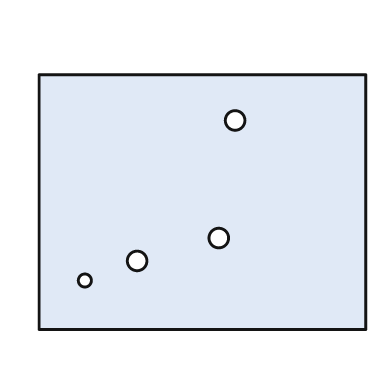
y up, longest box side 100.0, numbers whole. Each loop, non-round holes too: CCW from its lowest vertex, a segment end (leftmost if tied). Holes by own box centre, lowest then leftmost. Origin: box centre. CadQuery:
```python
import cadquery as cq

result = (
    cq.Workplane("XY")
    .moveTo(-50.0, -39.0)
    .lineTo(50.0, -39.0)
    .lineTo(50.0, 39.0)
    .lineTo(-50.0, 39.0)
    .close()
    .moveTo(-36.0, -24.0)
    .circle(2.0)
    .moveTo(-20.0, -18.0)
    .circle(3.0)
    .moveTo(5.0, -11.0)
    .circle(3.0)
    .moveTo(10.0, 25.0)
    .circle(3.0)
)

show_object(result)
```